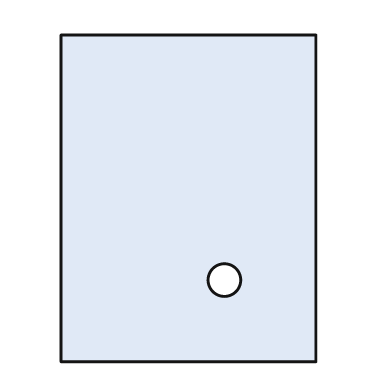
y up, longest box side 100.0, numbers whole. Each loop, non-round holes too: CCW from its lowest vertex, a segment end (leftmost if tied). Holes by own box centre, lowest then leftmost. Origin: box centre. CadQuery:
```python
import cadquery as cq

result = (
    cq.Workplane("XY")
    .moveTo(-39.0, -50.0)
    .lineTo(39.0, -50.0)
    .lineTo(39.0, 50.0)
    .lineTo(-39.0, 50.0)
    .close()
    .moveTo(11.0, -25.0)
    .circle(5.0)
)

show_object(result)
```